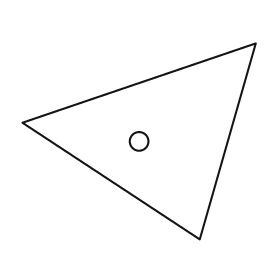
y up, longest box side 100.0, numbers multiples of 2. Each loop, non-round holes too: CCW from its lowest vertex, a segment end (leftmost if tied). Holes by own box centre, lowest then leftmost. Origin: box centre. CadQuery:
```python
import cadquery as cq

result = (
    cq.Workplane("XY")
    .moveTo(26.0, -42.0)
    .lineTo(50.0, 42.0)
    .lineTo(-50.0, 8.0)
    .close()
    .moveTo(0.0, 0.0)
    .circle(4.0)
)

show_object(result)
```